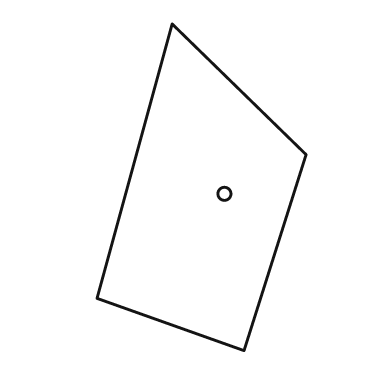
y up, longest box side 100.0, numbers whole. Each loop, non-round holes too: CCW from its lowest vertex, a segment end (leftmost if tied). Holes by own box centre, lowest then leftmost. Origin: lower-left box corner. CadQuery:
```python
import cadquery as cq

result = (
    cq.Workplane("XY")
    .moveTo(45.0, 0.0)
    .lineTo(64.0, 60.0)
    .lineTo(23.0, 100.0)
    .lineTo(0.0, 16.0)
    .close()
    .moveTo(39.0, 48.0)
    .circle(2.0)
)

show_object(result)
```